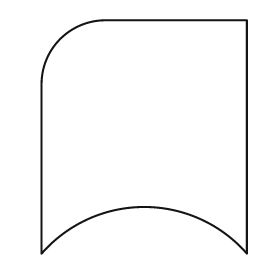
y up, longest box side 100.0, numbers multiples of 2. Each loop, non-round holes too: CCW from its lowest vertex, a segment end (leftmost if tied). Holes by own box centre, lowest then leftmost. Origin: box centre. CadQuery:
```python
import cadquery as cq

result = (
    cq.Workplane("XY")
    .moveTo(-44.0, -50.0)
    .threePointArc((0.0, -30.0), (44.0, -50.0))
    .lineTo(44.0, 50.0)
    .lineTo(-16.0, 50.0)
    .threePointArc((-36.0, 42.0), (-44.0, 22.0))
    .close()
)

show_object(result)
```